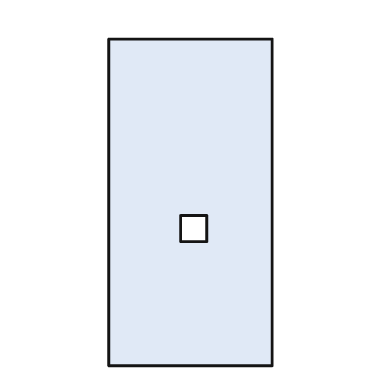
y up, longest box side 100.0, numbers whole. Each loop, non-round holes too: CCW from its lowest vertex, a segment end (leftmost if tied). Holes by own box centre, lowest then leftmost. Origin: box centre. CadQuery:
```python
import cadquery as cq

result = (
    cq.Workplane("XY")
    .moveTo(-25.0, -50.0)
    .lineTo(25.0, -50.0)
    .lineTo(25.0, 50.0)
    .lineTo(-25.0, 50.0)
    .close()
    .moveTo(-3.0, -12.0)
    .lineTo(5.0, -12.0)
    .lineTo(5.0, -4.0)
    .lineTo(-3.0, -4.0)
    .close()
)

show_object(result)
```